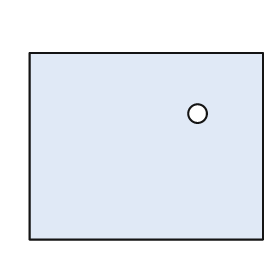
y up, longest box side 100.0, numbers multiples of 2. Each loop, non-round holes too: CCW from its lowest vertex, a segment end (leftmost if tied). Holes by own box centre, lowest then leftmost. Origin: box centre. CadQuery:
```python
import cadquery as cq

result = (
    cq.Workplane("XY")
    .moveTo(-50.0, -40.0)
    .lineTo(50.0, -40.0)
    .lineTo(50.0, 40.0)
    .lineTo(-50.0, 40.0)
    .close()
    .moveTo(22.0, 14.0)
    .circle(4.0)
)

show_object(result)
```